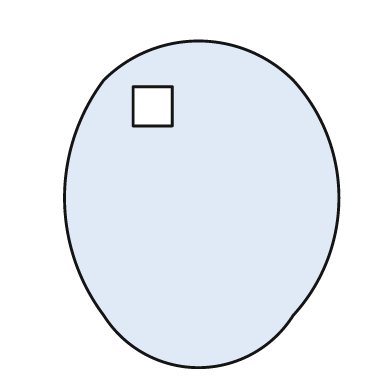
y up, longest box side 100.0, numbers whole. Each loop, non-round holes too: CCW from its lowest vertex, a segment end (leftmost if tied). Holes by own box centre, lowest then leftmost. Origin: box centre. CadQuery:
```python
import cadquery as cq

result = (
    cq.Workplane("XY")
    .moveTo(-30.0, -34.0)
    .threePointArc((-1.0, -50.0), (28.0, -34.0))
    .threePointArc((42.0, 2.0), (28.0, 38.0))
    .threePointArc((-1.0, 50.0), (-30.0, 38.0))
    .threePointArc((-42.0, 2.0), (-30.0, -34.0))
    .close()
    .moveTo(-21.0, 24.0)
    .lineTo(-9.0, 24.0)
    .lineTo(-9.0, 36.0)
    .lineTo(-21.0, 36.0)
    .close()
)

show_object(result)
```